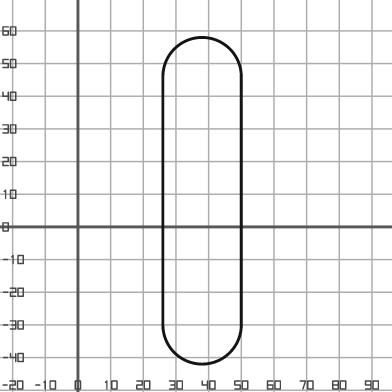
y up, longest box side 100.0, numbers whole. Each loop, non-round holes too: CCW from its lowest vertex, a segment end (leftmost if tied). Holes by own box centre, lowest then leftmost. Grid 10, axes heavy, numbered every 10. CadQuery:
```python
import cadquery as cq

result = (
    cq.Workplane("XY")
    .moveTo(26.0, -30.0)
    .threePointArc((38.0, -42.0), (50.0, -30.0))
    .lineTo(50.0, 46.0)
    .threePointArc((38.0, 58.0), (26.0, 46.0))
    .close()
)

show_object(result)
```